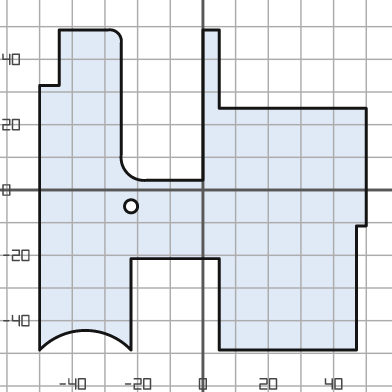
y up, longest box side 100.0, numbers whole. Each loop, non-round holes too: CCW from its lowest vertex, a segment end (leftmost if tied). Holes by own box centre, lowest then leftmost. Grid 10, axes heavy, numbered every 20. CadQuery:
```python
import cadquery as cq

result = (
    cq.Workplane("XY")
    .moveTo(-50.0, -49.0)
    .threePointArc((-36.0, -43.0), (-22.0, -49.0))
    .lineTo(-22.0, -21.0)
    .lineTo(5.0, -21.0)
    .lineTo(5.0, -49.0)
    .lineTo(47.0, -49.0)
    .lineTo(47.0, -11.0)
    .lineTo(50.0, -11.0)
    .lineTo(50.0, 25.0)
    .lineTo(5.0, 25.0)
    .lineTo(5.0, 49.0)
    .lineTo(0.0, 49.0)
    .lineTo(0.0, 3.0)
    .lineTo(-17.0, 3.0)
    .threePointArc((-23.0, 5.0), (-25.0, 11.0))
    .lineTo(-25.0, 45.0)
    .threePointArc((-26.0, 48.0), (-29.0, 49.0))
    .lineTo(-44.0, 49.0)
    .lineTo(-44.0, 32.0)
    .lineTo(-50.0, 32.0)
    .close()
    .moveTo(-22.0, -5.0)
    .circle(2.0)
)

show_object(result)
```